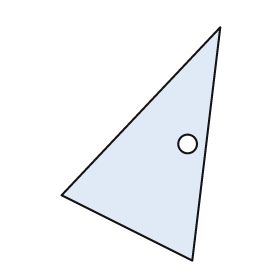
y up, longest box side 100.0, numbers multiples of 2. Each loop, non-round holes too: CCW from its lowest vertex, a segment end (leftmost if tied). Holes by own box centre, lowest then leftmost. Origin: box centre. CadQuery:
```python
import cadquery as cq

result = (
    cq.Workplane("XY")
    .moveTo(22.0, -50.0)
    .lineTo(34.0, 50.0)
    .lineTo(-34.0, -22.0)
    .close()
    .moveTo(20.0, 0.0)
    .circle(4.0)
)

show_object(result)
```